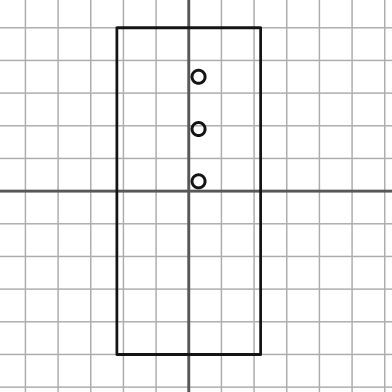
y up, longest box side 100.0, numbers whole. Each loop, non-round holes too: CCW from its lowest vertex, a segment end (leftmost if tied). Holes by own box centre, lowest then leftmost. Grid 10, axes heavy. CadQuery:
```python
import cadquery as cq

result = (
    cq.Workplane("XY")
    .moveTo(-22.0, -50.0)
    .lineTo(22.0, -50.0)
    .lineTo(22.0, 50.0)
    .lineTo(-22.0, 50.0)
    .close()
    .moveTo(3.0, 3.0)
    .circle(2.0)
    .moveTo(3.0, 19.0)
    .circle(2.0)
    .moveTo(3.0, 35.0)
    .circle(2.0)
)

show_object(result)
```